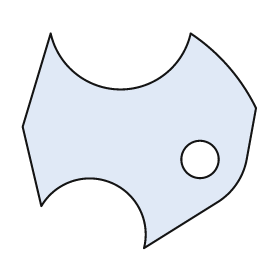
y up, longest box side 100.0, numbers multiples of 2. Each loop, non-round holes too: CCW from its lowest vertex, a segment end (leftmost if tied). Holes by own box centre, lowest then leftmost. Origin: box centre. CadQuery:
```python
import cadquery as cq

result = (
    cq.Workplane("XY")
    .moveTo(2.0, -46.0)
    .lineTo(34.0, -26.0)
    .threePointArc((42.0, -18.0), (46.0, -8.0))
    .lineTo(50.0, 14.0)
    .threePointArc((38.0, 32.0), (22.0, 46.0))
    .threePointArc((-8.0, 22.0), (-38.0, 46.0))
    .lineTo(-50.0, 6.0)
    .lineTo(-42.0, -28.0)
    .threePointArc((-12.0, -18.0), (2.0, -46.0))
    .close()
    .moveTo(26.0, -8.0)
    .circle(8.0)
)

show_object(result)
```